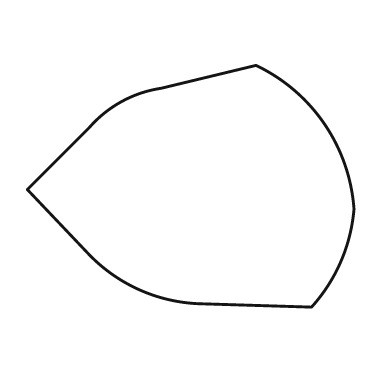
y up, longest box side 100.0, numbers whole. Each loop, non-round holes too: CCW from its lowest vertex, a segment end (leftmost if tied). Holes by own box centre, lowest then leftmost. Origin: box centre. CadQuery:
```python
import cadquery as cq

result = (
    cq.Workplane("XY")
    .moveTo(37.0, -37.0)
    .threePointArc((46.0, -23.0), (50.0, -7.0))
    .threePointArc((41.0, 19.0), (20.0, 37.0))
    .lineTo(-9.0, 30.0)
    .threePointArc((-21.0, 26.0), (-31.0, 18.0))
    .lineTo(-50.0, -1.0)
    .lineTo(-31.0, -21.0)
    .threePointArc((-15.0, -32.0), (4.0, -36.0))
    .close()
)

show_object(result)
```